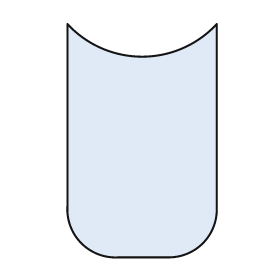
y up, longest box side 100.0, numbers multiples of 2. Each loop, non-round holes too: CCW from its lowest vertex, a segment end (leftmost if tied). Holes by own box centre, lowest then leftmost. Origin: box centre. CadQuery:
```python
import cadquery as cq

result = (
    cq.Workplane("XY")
    .moveTo(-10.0, -50.0)
    .lineTo(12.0, -50.0)
    .threePointArc((26.0, -44.0), (32.0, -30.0))
    .lineTo(32.0, 50.0)
    .threePointArc((0.0, 36.0), (-32.0, 50.0))
    .lineTo(-32.0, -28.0)
    .threePointArc((-26.0, -44.0), (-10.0, -50.0))
    .close()
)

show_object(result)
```